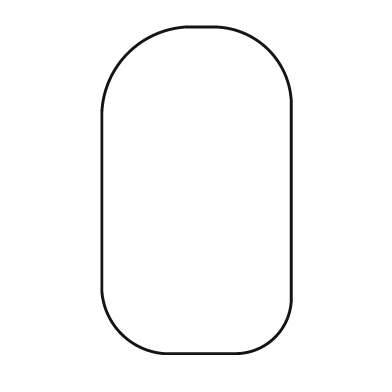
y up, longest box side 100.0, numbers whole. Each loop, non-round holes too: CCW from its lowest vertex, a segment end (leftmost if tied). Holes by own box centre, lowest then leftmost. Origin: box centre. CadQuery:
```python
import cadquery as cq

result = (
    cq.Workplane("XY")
    .moveTo(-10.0, -50.0)
    .lineTo(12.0, -50.0)
    .threePointArc((24.0, -45.0), (29.0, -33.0))
    .lineTo(29.0, 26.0)
    .threePointArc((22.0, 43.0), (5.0, 50.0))
    .lineTo(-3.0, 50.0)
    .threePointArc((-21.0, 42.0), (-29.0, 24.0))
    .lineTo(-29.0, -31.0)
    .threePointArc((-23.0, -44.0), (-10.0, -50.0))
    .close()
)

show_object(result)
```